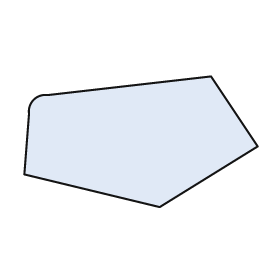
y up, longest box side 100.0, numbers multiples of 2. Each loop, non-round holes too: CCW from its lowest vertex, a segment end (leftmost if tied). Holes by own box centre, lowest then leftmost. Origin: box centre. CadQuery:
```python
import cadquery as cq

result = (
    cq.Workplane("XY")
    .moveTo(8.0, -28.0)
    .lineTo(50.0, -2.0)
    .lineTo(30.0, 28.0)
    .lineTo(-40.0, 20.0)
    .threePointArc((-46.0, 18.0), (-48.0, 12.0))
    .lineTo(-50.0, -14.0)
    .close()
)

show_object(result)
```